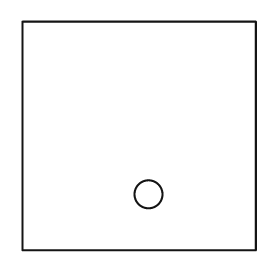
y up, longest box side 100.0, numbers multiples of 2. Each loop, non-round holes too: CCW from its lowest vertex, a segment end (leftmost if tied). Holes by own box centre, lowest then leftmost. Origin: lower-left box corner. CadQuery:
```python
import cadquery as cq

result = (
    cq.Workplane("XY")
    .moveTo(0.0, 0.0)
    .lineTo(100.0, 0.0)
    .lineTo(100.0, 98.0)
    .lineTo(0.0, 98.0)
    .close()
    .moveTo(54.0, 24.0)
    .circle(6.0)
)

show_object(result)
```